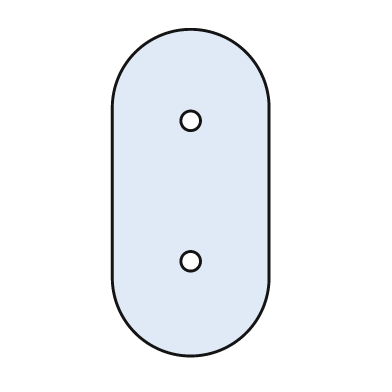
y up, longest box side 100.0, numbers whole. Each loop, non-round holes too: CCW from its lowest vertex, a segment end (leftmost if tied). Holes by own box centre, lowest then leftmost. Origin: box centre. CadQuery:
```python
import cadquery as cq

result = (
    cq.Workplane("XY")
    .moveTo(-24.0, -26.0)
    .threePointArc((0.0, -50.0), (24.0, -26.0))
    .lineTo(24.0, 26.0)
    .threePointArc((0.0, 50.0), (-24.0, 26.0))
    .close()
    .moveTo(0.0, -21.0)
    .circle(3.0)
    .moveTo(0.0, 22.0)
    .circle(3.0)
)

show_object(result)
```